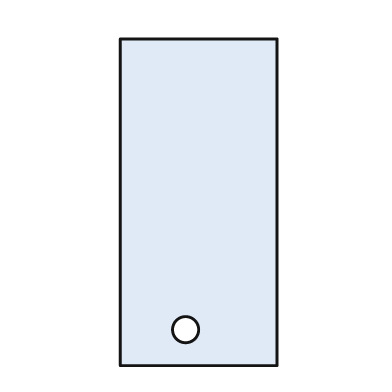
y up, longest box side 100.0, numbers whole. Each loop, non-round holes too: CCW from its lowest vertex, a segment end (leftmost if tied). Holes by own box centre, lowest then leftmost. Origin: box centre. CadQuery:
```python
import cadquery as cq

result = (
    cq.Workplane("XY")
    .moveTo(-24.0, -50.0)
    .lineTo(24.0, -50.0)
    .lineTo(24.0, 50.0)
    .lineTo(-24.0, 50.0)
    .close()
    .moveTo(-4.0, -39.0)
    .circle(4.0)
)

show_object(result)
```